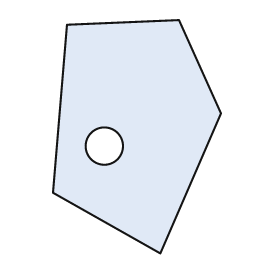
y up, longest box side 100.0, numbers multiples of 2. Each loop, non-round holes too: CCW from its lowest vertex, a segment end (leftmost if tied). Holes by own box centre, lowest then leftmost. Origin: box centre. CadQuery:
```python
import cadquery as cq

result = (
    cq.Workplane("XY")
    .moveTo(10.0, -50.0)
    .lineTo(36.0, 10.0)
    .lineTo(18.0, 50.0)
    .lineTo(-30.0, 48.0)
    .lineTo(-36.0, -24.0)
    .close()
    .moveTo(-14.0, -4.0)
    .circle(8.0)
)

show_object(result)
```